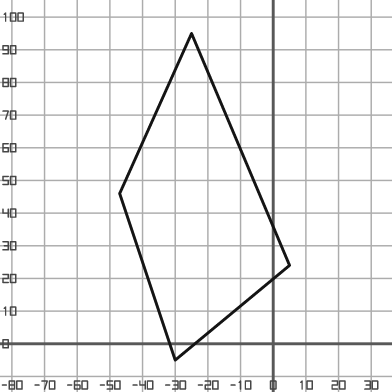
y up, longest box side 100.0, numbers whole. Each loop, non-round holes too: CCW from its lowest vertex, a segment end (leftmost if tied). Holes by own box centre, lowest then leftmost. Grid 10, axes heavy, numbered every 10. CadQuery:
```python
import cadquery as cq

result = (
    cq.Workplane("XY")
    .moveTo(-30.0, -5.0)
    .lineTo(5.0, 24.0)
    .lineTo(-25.0, 95.0)
    .lineTo(-47.0, 46.0)
    .close()
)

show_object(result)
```